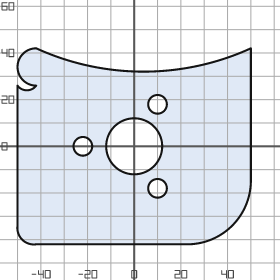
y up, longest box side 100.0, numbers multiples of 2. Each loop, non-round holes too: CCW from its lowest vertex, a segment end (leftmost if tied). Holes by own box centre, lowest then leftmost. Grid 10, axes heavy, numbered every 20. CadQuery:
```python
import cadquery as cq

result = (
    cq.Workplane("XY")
    .moveTo(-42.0, -42.0)
    .lineTo(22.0, -42.0)
    .threePointArc((42.0, -34.0), (50.0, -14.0))
    .lineTo(50.0, 42.0)
    .threePointArc((4.0, 32.0), (-42.0, 42.0))
    .threePointArc((-50.0, 34.0), (-42.0, 26.0))
    .threePointArc((-46.0, 24.0), (-50.0, 26.0))
    .lineTo(-50.0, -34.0)
    .threePointArc((-48.0, -40.0), (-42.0, -42.0))
    .close()
    .moveTo(10.0, -18.0)
    .circle(4.0)
    .moveTo(-22.0, 0.0)
    .circle(4.0)
    .moveTo(0.0, 0.0)
    .circle(12.0)
    .moveTo(10.0, 18.0)
    .circle(4.0)
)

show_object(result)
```